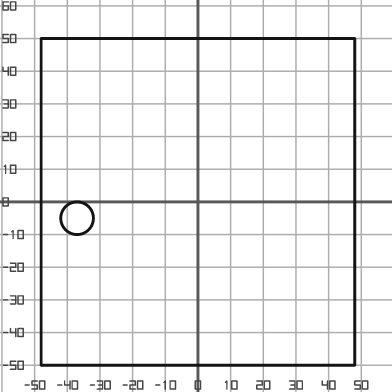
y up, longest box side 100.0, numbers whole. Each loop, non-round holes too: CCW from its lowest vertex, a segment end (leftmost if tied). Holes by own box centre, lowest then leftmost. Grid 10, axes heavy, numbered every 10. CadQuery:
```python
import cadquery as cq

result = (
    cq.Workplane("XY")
    .moveTo(-48.0, -50.0)
    .lineTo(48.0, -50.0)
    .lineTo(48.0, 50.0)
    .lineTo(-48.0, 50.0)
    .close()
    .moveTo(-37.0, -5.0)
    .circle(5.0)
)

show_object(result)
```